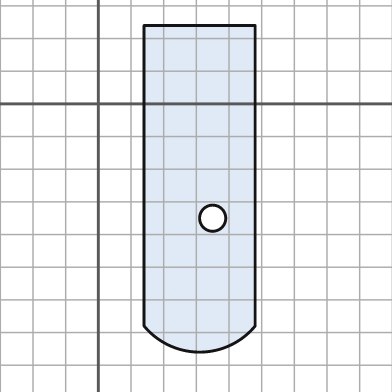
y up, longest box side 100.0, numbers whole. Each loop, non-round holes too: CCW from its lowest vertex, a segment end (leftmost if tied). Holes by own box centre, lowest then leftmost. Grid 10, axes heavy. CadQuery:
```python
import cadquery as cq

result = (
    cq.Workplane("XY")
    .moveTo(14.0, -68.0)
    .threePointArc((31.0, -76.0), (48.0, -68.0))
    .lineTo(48.0, 24.0)
    .lineTo(14.0, 24.0)
    .close()
    .moveTo(35.0, -35.0)
    .circle(4.0)
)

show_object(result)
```